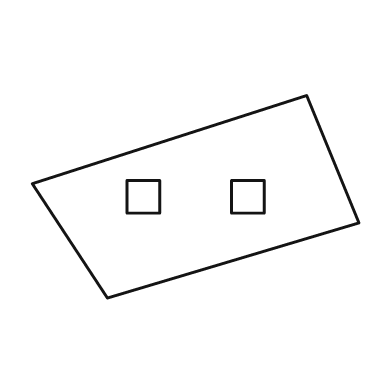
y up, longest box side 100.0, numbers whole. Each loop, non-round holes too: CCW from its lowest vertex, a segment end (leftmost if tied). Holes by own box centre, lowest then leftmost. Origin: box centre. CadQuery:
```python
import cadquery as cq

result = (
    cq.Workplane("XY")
    .moveTo(-27.0, -31.0)
    .lineTo(50.0, -8.0)
    .lineTo(34.0, 31.0)
    .lineTo(-50.0, 4.0)
    .close()
    .moveTo(-21.0, -5.0)
    .lineTo(-11.0, -5.0)
    .lineTo(-11.0, 5.0)
    .lineTo(-21.0, 5.0)
    .close()
    .moveTo(11.0, -5.0)
    .lineTo(21.0, -5.0)
    .lineTo(21.0, 5.0)
    .lineTo(11.0, 5.0)
    .close()
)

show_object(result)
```